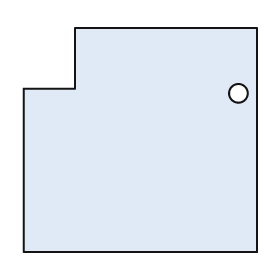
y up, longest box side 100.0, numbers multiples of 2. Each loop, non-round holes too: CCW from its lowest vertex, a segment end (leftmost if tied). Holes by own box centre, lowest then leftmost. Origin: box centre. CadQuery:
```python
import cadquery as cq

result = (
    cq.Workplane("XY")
    .moveTo(-50.0, -48.0)
    .lineTo(50.0, -48.0)
    .lineTo(50.0, 48.0)
    .lineTo(-28.0, 48.0)
    .lineTo(-28.0, 22.0)
    .lineTo(-50.0, 22.0)
    .close()
    .moveTo(42.0, 20.0)
    .circle(4.0)
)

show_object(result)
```